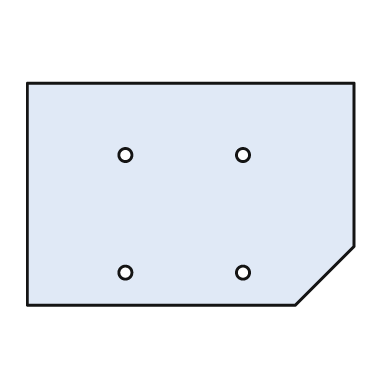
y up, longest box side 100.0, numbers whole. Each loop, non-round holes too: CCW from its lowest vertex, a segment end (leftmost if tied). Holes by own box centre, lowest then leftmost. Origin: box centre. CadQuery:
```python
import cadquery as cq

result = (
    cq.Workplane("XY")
    .moveTo(-50.0, -34.0)
    .lineTo(32.0, -34.0)
    .lineTo(50.0, -16.0)
    .lineTo(50.0, 34.0)
    .lineTo(-50.0, 34.0)
    .close()
    .moveTo(-20.0, -24.0)
    .circle(2.0)
    .moveTo(16.0, -24.0)
    .circle(2.0)
    .moveTo(-20.0, 12.0)
    .circle(2.0)
    .moveTo(16.0, 12.0)
    .circle(2.0)
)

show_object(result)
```